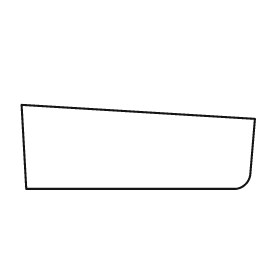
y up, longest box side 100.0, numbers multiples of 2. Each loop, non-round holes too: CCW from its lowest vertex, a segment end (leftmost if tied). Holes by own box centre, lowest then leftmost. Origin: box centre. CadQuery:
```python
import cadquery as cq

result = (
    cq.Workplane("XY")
    .moveTo(-48.0, -18.0)
    .lineTo(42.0, -18.0)
    .threePointArc((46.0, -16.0), (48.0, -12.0))
    .lineTo(50.0, 12.0)
    .lineTo(-50.0, 18.0)
    .close()
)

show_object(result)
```